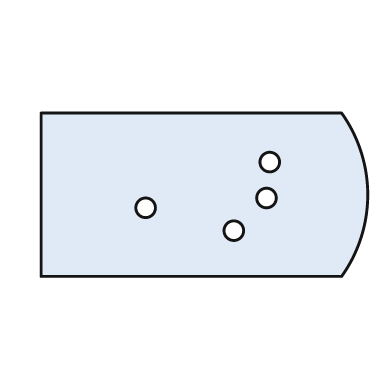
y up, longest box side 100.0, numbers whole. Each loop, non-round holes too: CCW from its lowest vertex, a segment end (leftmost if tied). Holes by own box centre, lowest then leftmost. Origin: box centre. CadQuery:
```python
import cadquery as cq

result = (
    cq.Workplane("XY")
    .moveTo(-50.0, -25.0)
    .lineTo(42.0, -25.0)
    .threePointArc((50.0, 0.0), (42.0, 25.0))
    .lineTo(-50.0, 25.0)
    .close()
    .moveTo(9.0, -11.0)
    .circle(3.0)
    .moveTo(-18.0, -4.0)
    .circle(3.0)
    .moveTo(19.0, -1.0)
    .circle(3.0)
    .moveTo(20.0, 10.0)
    .circle(3.0)
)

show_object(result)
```